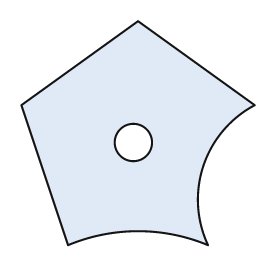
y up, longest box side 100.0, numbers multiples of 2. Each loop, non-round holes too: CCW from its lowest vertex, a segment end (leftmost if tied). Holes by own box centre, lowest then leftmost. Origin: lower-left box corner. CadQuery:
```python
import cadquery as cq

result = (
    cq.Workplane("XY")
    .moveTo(20.0, 0.0)
    .threePointArc((50.0, 6.0), (80.0, 0.0))
    .threePointArc((78.0, 34.0), (100.0, 60.0))
    .lineTo(50.0, 96.0)
    .lineTo(0.0, 60.0)
    .close()
    .moveTo(48.0, 44.0)
    .circle(8.0)
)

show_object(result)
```